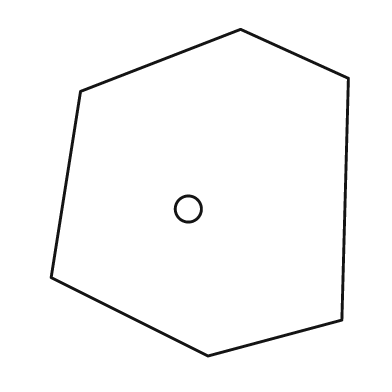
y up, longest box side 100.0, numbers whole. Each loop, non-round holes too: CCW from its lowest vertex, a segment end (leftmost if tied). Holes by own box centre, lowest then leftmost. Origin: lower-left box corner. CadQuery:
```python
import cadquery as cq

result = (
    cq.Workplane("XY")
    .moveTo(48.0, 0.0)
    .lineTo(89.0, 11.0)
    .lineTo(91.0, 85.0)
    .lineTo(58.0, 100.0)
    .lineTo(9.0, 81.0)
    .lineTo(0.0, 24.0)
    .close()
    .moveTo(42.0, 45.0)
    .circle(4.0)
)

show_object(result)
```